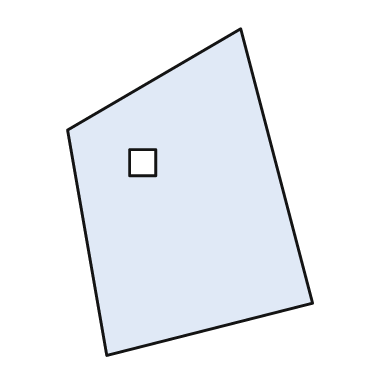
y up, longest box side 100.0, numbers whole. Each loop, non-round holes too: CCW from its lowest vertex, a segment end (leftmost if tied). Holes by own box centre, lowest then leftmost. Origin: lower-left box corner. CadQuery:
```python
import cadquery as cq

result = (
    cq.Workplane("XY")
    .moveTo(12.0, 0.0)
    .lineTo(75.0, 16.0)
    .lineTo(53.0, 100.0)
    .lineTo(0.0, 69.0)
    .close()
    .moveTo(19.0, 55.0)
    .lineTo(27.0, 55.0)
    .lineTo(27.0, 63.0)
    .lineTo(19.0, 63.0)
    .close()
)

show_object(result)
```